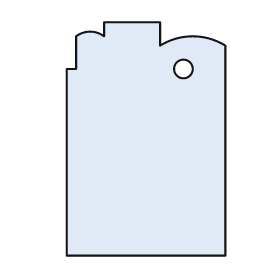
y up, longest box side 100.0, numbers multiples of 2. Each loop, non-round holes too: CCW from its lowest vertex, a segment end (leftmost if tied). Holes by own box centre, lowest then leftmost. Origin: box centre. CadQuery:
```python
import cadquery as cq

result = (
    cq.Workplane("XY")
    .moveTo(-34.0, -50.0)
    .lineTo(34.0, -50.0)
    .lineTo(34.0, 40.0)
    .threePointArc((20.0, 44.0), (6.0, 40.0))
    .lineTo(6.0, 50.0)
    .lineTo(-18.0, 50.0)
    .lineTo(-18.0, 44.0)
    .threePointArc((-24.0, 46.0), (-30.0, 44.0))
    .lineTo(-30.0, 30.0)
    .lineTo(-34.0, 30.0)
    .close()
    .moveTo(16.0, 30.0)
    .circle(4.0)
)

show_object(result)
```